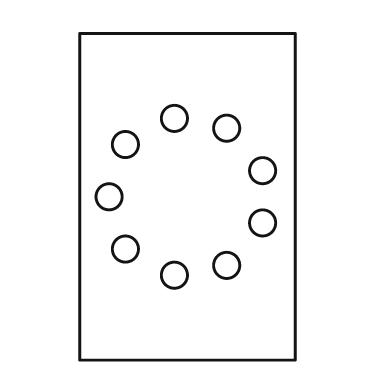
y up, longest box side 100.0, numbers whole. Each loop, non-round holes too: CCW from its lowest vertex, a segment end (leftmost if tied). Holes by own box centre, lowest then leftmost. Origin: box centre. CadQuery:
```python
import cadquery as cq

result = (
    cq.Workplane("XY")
    .moveTo(-33.0, -50.0)
    .lineTo(33.0, -50.0)
    .lineTo(33.0, 50.0)
    .lineTo(-33.0, 50.0)
    .close()
    .moveTo(-4.0, -24.0)
    .circle(4.0)
    .moveTo(12.0, -21.0)
    .circle(4.0)
    .moveTo(-19.0, -16.0)
    .circle(4.0)
    .moveTo(23.0, -8.0)
    .circle(4.0)
    .moveTo(-24.0, 0.0)
    .circle(4.0)
    .moveTo(23.0, 8.0)
    .circle(4.0)
    .moveTo(-19.0, 16.0)
    .circle(4.0)
    .moveTo(12.0, 21.0)
    .circle(4.0)
    .moveTo(-4.0, 24.0)
    .circle(4.0)
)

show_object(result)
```